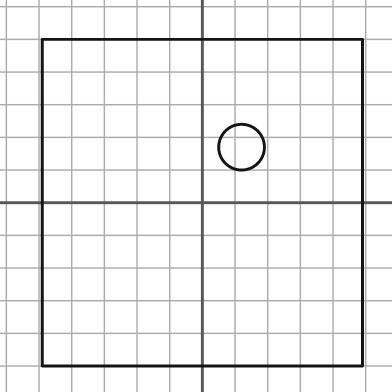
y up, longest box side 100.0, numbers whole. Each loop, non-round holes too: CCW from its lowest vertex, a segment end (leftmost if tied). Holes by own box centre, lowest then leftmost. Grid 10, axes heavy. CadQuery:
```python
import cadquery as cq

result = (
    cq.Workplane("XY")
    .moveTo(-49.0, -50.0)
    .lineTo(49.0, -50.0)
    .lineTo(49.0, 50.0)
    .lineTo(-49.0, 50.0)
    .close()
    .moveTo(12.0, 17.0)
    .circle(7.0)
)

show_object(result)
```